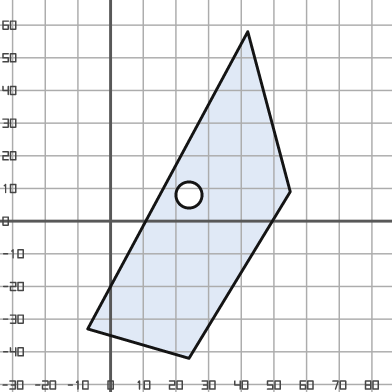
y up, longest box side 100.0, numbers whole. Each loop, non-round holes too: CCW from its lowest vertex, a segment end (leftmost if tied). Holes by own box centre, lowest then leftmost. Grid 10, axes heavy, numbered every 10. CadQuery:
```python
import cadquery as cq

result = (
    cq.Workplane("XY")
    .moveTo(24.0, -42.0)
    .lineTo(55.0, 9.0)
    .lineTo(42.0, 58.0)
    .lineTo(-7.0, -33.0)
    .close()
    .moveTo(24.0, 8.0)
    .circle(4.0)
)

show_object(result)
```